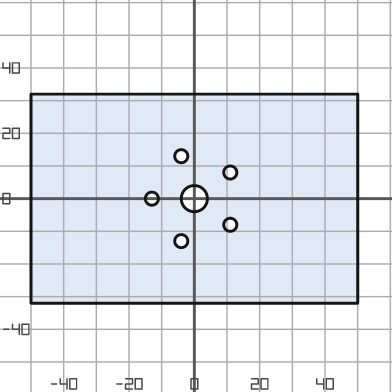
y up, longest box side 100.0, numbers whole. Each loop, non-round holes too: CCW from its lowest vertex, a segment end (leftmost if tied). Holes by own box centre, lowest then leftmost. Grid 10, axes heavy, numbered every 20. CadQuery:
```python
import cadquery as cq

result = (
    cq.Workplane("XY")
    .moveTo(-50.0, -32.0)
    .lineTo(50.0, -32.0)
    .lineTo(50.0, 32.0)
    .lineTo(-50.0, 32.0)
    .close()
    .moveTo(-4.0, -13.0)
    .circle(2.0)
    .moveTo(11.0, -8.0)
    .circle(2.0)
    .moveTo(-13.0, 0.0)
    .circle(2.0)
    .moveTo(0.0, 0.0)
    .circle(4.0)
    .moveTo(11.0, 8.0)
    .circle(2.0)
    .moveTo(-4.0, 13.0)
    .circle(2.0)
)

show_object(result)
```